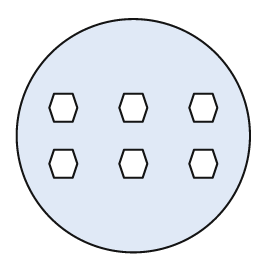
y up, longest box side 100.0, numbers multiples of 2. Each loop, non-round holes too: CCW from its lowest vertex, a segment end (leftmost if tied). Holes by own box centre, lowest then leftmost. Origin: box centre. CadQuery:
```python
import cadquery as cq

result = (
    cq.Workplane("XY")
    .moveTo(0.0, 0.0)
    .circle(50.0)
    .moveTo(-34.0, -18.0)
    .lineTo(-26.0, -18.0)
    .lineTo(-24.0, -12.0)
    .lineTo(-26.0, -6.0)
    .lineTo(-34.0, -6.0)
    .lineTo(-36.0, -12.0)
    .close()
    .moveTo(-4.0, -18.0)
    .lineTo(4.0, -18.0)
    .lineTo(6.0, -12.0)
    .lineTo(4.0, -6.0)
    .lineTo(-4.0, -6.0)
    .lineTo(-6.0, -12.0)
    .close()
    .moveTo(26.0, -18.0)
    .lineTo(34.0, -18.0)
    .lineTo(36.0, -12.0)
    .lineTo(34.0, -6.0)
    .lineTo(26.0, -6.0)
    .lineTo(24.0, -12.0)
    .close()
    .moveTo(-34.0, 6.0)
    .lineTo(-26.0, 6.0)
    .lineTo(-24.0, 12.0)
    .lineTo(-26.0, 18.0)
    .lineTo(-34.0, 18.0)
    .lineTo(-36.0, 12.0)
    .close()
    .moveTo(-4.0, 6.0)
    .lineTo(4.0, 6.0)
    .lineTo(6.0, 12.0)
    .lineTo(4.0, 18.0)
    .lineTo(-4.0, 18.0)
    .lineTo(-6.0, 12.0)
    .close()
    .moveTo(26.0, 6.0)
    .lineTo(34.0, 6.0)
    .lineTo(36.0, 12.0)
    .lineTo(34.0, 18.0)
    .lineTo(26.0, 18.0)
    .lineTo(24.0, 12.0)
    .close()
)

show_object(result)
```